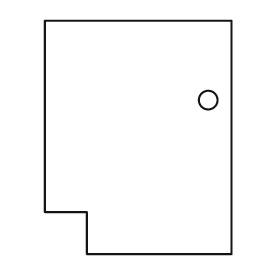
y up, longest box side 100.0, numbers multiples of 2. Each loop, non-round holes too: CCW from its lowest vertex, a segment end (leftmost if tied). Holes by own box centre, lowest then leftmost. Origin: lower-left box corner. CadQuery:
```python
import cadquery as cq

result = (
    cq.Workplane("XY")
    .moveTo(18.0, 0.0)
    .lineTo(80.0, 0.0)
    .lineTo(80.0, 100.0)
    .lineTo(0.0, 100.0)
    .lineTo(0.0, 18.0)
    .lineTo(18.0, 18.0)
    .close()
    .moveTo(70.0, 66.0)
    .circle(4.0)
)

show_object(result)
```